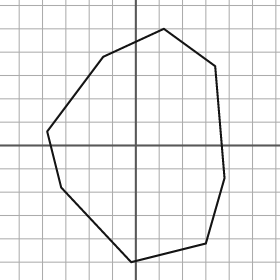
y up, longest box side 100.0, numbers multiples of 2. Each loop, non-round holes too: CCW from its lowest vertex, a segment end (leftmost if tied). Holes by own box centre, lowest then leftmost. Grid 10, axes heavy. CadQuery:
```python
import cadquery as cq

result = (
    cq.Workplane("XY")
    .moveTo(-2.0, -50.0)
    .lineTo(30.0, -42.0)
    .lineTo(38.0, -14.0)
    .lineTo(34.0, 34.0)
    .lineTo(12.0, 50.0)
    .lineTo(-14.0, 38.0)
    .lineTo(-38.0, 6.0)
    .lineTo(-32.0, -18.0)
    .close()
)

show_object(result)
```